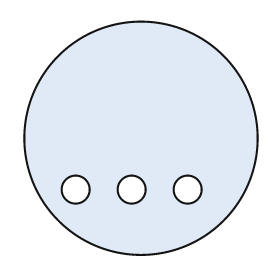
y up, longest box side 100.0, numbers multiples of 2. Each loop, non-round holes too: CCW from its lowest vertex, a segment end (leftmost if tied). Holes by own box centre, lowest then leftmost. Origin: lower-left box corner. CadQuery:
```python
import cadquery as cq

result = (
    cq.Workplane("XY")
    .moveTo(50.0, 50.0)
    .circle(50.0)
    .moveTo(22.0, 28.0)
    .circle(6.0)
    .moveTo(46.0, 28.0)
    .circle(6.0)
    .moveTo(70.0, 28.0)
    .circle(6.0)
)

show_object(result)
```